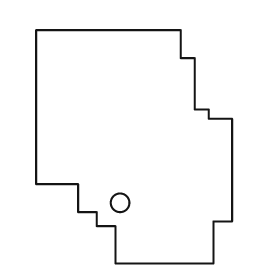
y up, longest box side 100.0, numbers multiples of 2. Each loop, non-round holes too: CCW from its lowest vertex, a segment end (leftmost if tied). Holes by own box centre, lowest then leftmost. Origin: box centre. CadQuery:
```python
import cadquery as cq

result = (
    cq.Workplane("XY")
    .moveTo(-8.0, -50.0)
    .lineTo(34.0, -50.0)
    .lineTo(34.0, -32.0)
    .lineTo(42.0, -32.0)
    .lineTo(42.0, 12.0)
    .lineTo(32.0, 12.0)
    .lineTo(32.0, 16.0)
    .lineTo(26.0, 16.0)
    .lineTo(26.0, 38.0)
    .lineTo(20.0, 38.0)
    .lineTo(20.0, 50.0)
    .lineTo(-42.0, 50.0)
    .lineTo(-42.0, -16.0)
    .lineTo(-24.0, -16.0)
    .lineTo(-24.0, -28.0)
    .lineTo(-16.0, -28.0)
    .lineTo(-16.0, -34.0)
    .lineTo(-8.0, -34.0)
    .close()
    .moveTo(-6.0, -24.0)
    .circle(4.0)
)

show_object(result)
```